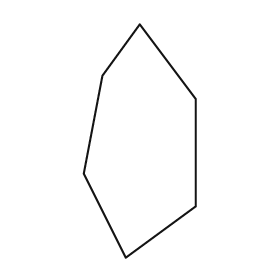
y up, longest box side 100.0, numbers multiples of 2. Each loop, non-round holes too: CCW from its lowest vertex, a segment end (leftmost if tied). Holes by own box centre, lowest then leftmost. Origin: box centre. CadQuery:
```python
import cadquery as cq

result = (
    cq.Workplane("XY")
    .moveTo(-6.0, -50.0)
    .lineTo(24.0, -28.0)
    .lineTo(24.0, 18.0)
    .lineTo(0.0, 50.0)
    .lineTo(-16.0, 28.0)
    .lineTo(-24.0, -14.0)
    .close()
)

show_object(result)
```